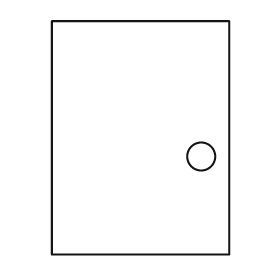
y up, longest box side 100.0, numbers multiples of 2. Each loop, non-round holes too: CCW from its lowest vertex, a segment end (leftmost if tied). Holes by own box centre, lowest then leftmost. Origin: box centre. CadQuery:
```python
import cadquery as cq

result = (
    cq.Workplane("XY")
    .moveTo(-38.0, -50.0)
    .lineTo(38.0, -50.0)
    .lineTo(38.0, 50.0)
    .lineTo(-38.0, 50.0)
    .close()
    .moveTo(26.0, -8.0)
    .circle(6.0)
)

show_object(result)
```